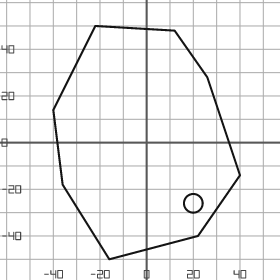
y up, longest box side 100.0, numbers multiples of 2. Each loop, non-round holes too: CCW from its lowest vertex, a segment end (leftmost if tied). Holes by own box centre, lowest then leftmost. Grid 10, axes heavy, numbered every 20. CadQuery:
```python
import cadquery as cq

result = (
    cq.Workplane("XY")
    .moveTo(-16.0, -50.0)
    .lineTo(22.0, -40.0)
    .lineTo(40.0, -14.0)
    .lineTo(26.0, 28.0)
    .lineTo(12.0, 48.0)
    .lineTo(-22.0, 50.0)
    .lineTo(-40.0, 14.0)
    .lineTo(-36.0, -18.0)
    .close()
    .moveTo(20.0, -26.0)
    .circle(4.0)
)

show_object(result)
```